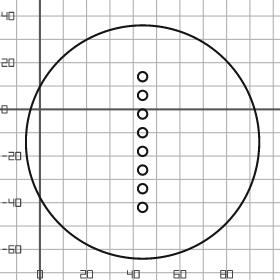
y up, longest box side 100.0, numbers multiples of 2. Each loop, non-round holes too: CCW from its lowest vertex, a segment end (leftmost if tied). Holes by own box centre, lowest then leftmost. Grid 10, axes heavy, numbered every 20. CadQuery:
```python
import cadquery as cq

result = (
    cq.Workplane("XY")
    .moveTo(44.0, -14.0)
    .circle(50.0)
    .moveTo(44.0, -42.0)
    .circle(2.0)
    .moveTo(44.0, -34.0)
    .circle(2.0)
    .moveTo(44.0, -26.0)
    .circle(2.0)
    .moveTo(44.0, -18.0)
    .circle(2.0)
    .moveTo(44.0, -10.0)
    .circle(2.0)
    .moveTo(44.0, -2.0)
    .circle(2.0)
    .moveTo(44.0, 6.0)
    .circle(2.0)
    .moveTo(44.0, 14.0)
    .circle(2.0)
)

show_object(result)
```